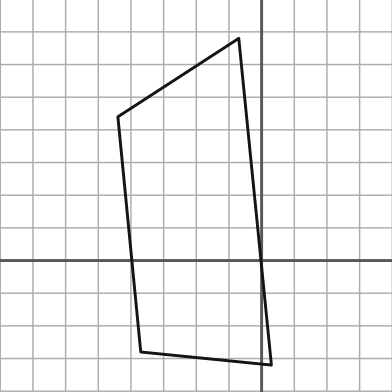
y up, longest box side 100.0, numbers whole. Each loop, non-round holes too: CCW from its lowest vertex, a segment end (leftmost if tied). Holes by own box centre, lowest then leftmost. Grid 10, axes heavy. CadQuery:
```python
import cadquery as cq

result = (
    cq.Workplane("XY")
    .moveTo(3.0, -32.0)
    .lineTo(-7.0, 68.0)
    .lineTo(-44.0, 44.0)
    .lineTo(-37.0, -28.0)
    .close()
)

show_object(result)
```